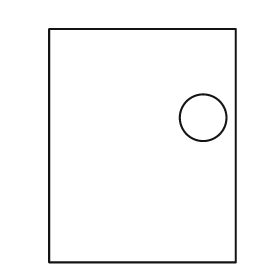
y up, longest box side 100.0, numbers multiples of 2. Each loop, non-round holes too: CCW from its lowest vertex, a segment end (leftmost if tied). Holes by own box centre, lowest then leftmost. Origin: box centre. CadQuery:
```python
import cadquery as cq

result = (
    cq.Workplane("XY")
    .moveTo(-40.0, -50.0)
    .lineTo(40.0, -50.0)
    .lineTo(40.0, 50.0)
    .lineTo(-40.0, 50.0)
    .close()
    .moveTo(26.0, 12.0)
    .circle(10.0)
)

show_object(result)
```